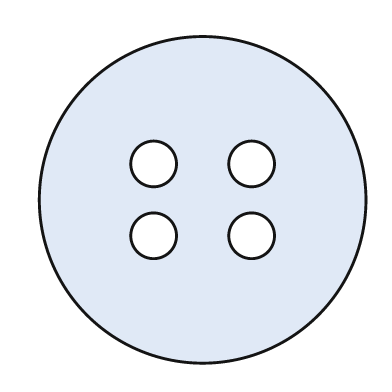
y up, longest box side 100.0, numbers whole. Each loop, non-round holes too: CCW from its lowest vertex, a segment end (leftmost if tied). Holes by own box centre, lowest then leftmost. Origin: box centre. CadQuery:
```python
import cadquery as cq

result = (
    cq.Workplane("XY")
    .moveTo(0.0, 0.0)
    .circle(50.0)
    .moveTo(-15.0, -11.0)
    .circle(7.0)
    .moveTo(15.0, -11.0)
    .circle(7.0)
    .moveTo(-15.0, 11.0)
    .circle(7.0)
    .moveTo(15.0, 11.0)
    .circle(7.0)
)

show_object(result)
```